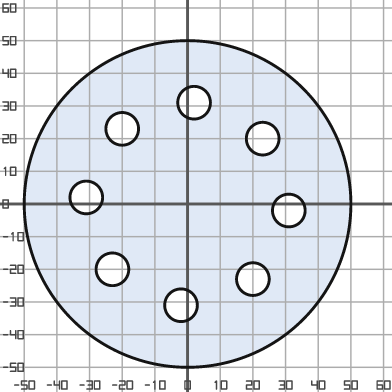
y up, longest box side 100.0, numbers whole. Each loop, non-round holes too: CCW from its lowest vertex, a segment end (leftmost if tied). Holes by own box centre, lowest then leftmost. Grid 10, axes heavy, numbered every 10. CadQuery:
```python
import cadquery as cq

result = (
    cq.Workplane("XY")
    .moveTo(0.0, 0.0)
    .circle(50.0)
    .moveTo(-2.0, -31.0)
    .circle(5.0)
    .moveTo(20.0, -23.0)
    .circle(5.0)
    .moveTo(-23.0, -20.0)
    .circle(5.0)
    .moveTo(31.0, -2.0)
    .circle(5.0)
    .moveTo(-31.0, 2.0)
    .circle(5.0)
    .moveTo(23.0, 20.0)
    .circle(5.0)
    .moveTo(-20.0, 23.0)
    .circle(5.0)
    .moveTo(2.0, 31.0)
    .circle(5.0)
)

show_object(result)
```